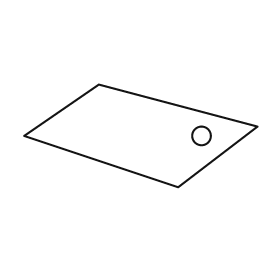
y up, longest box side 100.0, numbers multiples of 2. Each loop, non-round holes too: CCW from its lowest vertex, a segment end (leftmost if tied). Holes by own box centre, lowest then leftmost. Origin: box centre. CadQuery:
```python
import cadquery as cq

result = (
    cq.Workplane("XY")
    .moveTo(16.0, -22.0)
    .lineTo(50.0, 4.0)
    .lineTo(-18.0, 22.0)
    .lineTo(-50.0, 0.0)
    .close()
    .moveTo(26.0, 0.0)
    .circle(4.0)
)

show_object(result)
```